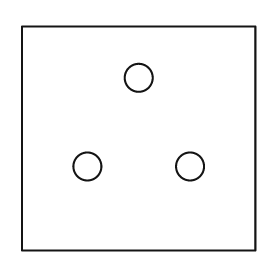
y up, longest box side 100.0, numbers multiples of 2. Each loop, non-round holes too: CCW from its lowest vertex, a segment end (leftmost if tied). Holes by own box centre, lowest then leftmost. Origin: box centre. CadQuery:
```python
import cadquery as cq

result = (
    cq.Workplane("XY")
    .moveTo(-50.0, -48.0)
    .lineTo(50.0, -48.0)
    .lineTo(50.0, 48.0)
    .lineTo(-50.0, 48.0)
    .close()
    .moveTo(-22.0, -12.0)
    .circle(6.0)
    .moveTo(22.0, -12.0)
    .circle(6.0)
    .moveTo(0.0, 26.0)
    .circle(6.0)
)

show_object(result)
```